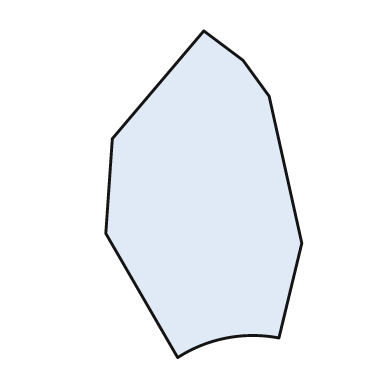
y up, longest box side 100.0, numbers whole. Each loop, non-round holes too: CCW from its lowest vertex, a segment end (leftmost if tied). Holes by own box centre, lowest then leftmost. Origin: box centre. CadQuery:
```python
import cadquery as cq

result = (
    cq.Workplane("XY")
    .moveTo(-8.0, -50.0)
    .threePointArc((7.0, -44.0), (23.0, -44.0))
    .lineTo(30.0, -15.0)
    .lineTo(20.0, 30.0)
    .lineTo(12.0, 41.0)
    .lineTo(0.0, 50.0)
    .lineTo(-28.0, 17.0)
    .lineTo(-30.0, -12.0)
    .close()
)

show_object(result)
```